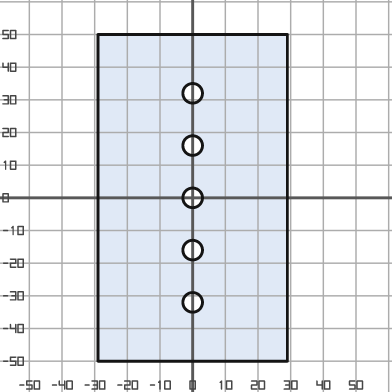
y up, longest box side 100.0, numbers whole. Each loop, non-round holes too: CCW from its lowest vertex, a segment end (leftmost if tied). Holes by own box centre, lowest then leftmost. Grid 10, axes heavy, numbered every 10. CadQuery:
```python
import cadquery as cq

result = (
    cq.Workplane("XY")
    .moveTo(-29.0, -50.0)
    .lineTo(29.0, -50.0)
    .lineTo(29.0, 50.0)
    .lineTo(-29.0, 50.0)
    .close()
    .moveTo(0.0, -32.0)
    .circle(3.0)
    .moveTo(0.0, -16.0)
    .circle(3.0)
    .moveTo(0.0, 0.0)
    .circle(3.0)
    .moveTo(0.0, 16.0)
    .circle(3.0)
    .moveTo(0.0, 32.0)
    .circle(3.0)
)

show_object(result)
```